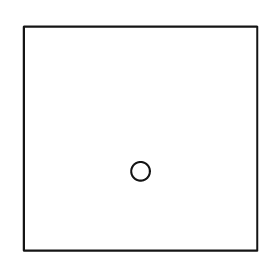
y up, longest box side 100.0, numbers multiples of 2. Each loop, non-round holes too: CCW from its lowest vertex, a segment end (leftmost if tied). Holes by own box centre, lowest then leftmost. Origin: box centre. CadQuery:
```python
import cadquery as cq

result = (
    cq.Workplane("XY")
    .moveTo(-50.0, -48.0)
    .lineTo(50.0, -48.0)
    .lineTo(50.0, 48.0)
    .lineTo(-50.0, 48.0)
    .close()
    .moveTo(0.0, -14.0)
    .circle(4.0)
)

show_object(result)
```